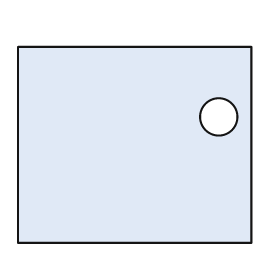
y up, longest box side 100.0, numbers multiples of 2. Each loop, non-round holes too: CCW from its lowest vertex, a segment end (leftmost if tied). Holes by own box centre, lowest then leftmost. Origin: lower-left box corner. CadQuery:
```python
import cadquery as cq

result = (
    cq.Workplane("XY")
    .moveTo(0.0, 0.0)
    .lineTo(100.0, 0.0)
    .lineTo(100.0, 84.0)
    .lineTo(0.0, 84.0)
    .close()
    .moveTo(86.0, 54.0)
    .circle(8.0)
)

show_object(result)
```